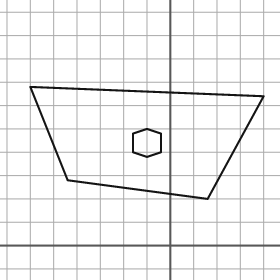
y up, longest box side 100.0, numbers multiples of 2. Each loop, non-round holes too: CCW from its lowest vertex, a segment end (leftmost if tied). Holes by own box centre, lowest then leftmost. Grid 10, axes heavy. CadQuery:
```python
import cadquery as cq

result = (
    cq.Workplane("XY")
    .moveTo(16.0, 20.0)
    .lineTo(40.0, 64.0)
    .lineTo(-60.0, 68.0)
    .lineTo(-44.0, 28.0)
    .close()
    .moveTo(-10.0, 38.0)
    .lineTo(-4.0, 40.0)
    .lineTo(-4.0, 48.0)
    .lineTo(-10.0, 50.0)
    .lineTo(-16.0, 48.0)
    .lineTo(-16.0, 40.0)
    .close()
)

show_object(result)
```